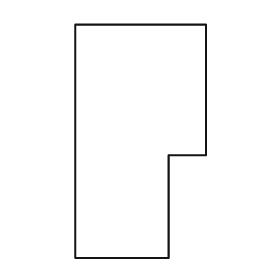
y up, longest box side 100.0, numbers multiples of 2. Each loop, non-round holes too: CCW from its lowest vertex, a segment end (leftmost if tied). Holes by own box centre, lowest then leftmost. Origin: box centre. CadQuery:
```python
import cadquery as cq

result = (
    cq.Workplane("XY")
    .moveTo(-28.0, -50.0)
    .lineTo(12.0, -50.0)
    .lineTo(12.0, -6.0)
    .lineTo(28.0, -6.0)
    .lineTo(28.0, 50.0)
    .lineTo(-28.0, 50.0)
    .close()
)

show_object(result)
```